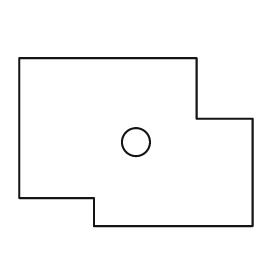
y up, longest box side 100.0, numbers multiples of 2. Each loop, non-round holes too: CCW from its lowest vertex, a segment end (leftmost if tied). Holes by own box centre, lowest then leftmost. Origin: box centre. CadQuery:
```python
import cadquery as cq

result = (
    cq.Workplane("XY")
    .moveTo(-18.0, -36.0)
    .lineTo(50.0, -36.0)
    .lineTo(50.0, 10.0)
    .lineTo(26.0, 10.0)
    .lineTo(26.0, 36.0)
    .lineTo(-50.0, 36.0)
    .lineTo(-50.0, -24.0)
    .lineTo(-18.0, -24.0)
    .close()
    .moveTo(0.0, 0.0)
    .circle(6.0)
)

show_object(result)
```